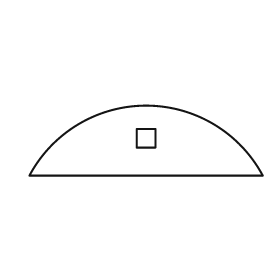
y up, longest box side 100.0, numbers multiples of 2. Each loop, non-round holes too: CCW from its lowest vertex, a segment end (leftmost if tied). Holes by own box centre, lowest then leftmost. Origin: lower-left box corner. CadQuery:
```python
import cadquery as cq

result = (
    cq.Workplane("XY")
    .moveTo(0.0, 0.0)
    .lineTo(100.0, 0.0)
    .threePointArc((50.0, 30.0), (0.0, 0.0))
    .close()
    .moveTo(46.0, 12.0)
    .lineTo(54.0, 12.0)
    .lineTo(54.0, 20.0)
    .lineTo(46.0, 20.0)
    .close()
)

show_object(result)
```